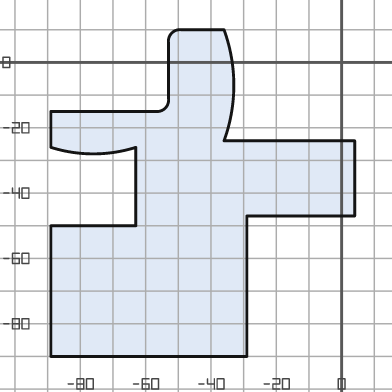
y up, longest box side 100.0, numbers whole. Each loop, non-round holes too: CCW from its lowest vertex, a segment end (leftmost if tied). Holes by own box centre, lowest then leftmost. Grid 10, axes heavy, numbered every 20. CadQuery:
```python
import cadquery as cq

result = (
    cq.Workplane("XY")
    .moveTo(-89.0, -90.0)
    .lineTo(-29.0, -90.0)
    .lineTo(-29.0, -47.0)
    .lineTo(4.0, -47.0)
    .lineTo(4.0, -24.0)
    .lineTo(-36.0, -24.0)
    .threePointArc((-33.0, -7.0), (-36.0, 10.0))
    .lineTo(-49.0, 10.0)
    .threePointArc((-52.0, 9.0), (-53.0, 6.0))
    .lineTo(-53.0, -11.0)
    .threePointArc((-54.0, -14.0), (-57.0, -15.0))
    .lineTo(-89.0, -15.0)
    .lineTo(-89.0, -26.0)
    .threePointArc((-76.0, -28.0), (-63.0, -26.0))
    .lineTo(-63.0, -50.0)
    .lineTo(-89.0, -50.0)
    .close()
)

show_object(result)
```